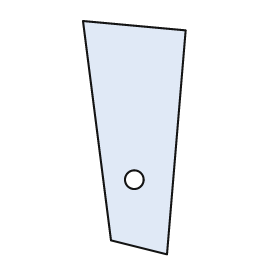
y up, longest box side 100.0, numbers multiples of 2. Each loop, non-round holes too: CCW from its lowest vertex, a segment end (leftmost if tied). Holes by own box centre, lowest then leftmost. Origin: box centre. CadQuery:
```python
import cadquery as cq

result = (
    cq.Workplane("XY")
    .moveTo(14.0, -50.0)
    .lineTo(22.0, 46.0)
    .lineTo(-22.0, 50.0)
    .lineTo(-10.0, -44.0)
    .close()
    .moveTo(0.0, -18.0)
    .circle(4.0)
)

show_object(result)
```